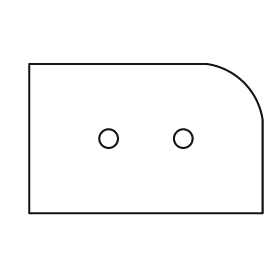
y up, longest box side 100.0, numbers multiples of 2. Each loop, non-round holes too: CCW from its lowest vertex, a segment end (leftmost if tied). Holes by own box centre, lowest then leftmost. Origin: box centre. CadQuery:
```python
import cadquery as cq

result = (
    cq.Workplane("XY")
    .moveTo(-50.0, -32.0)
    .lineTo(50.0, -32.0)
    .lineTo(50.0, 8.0)
    .threePointArc((42.0, 24.0), (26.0, 32.0))
    .lineTo(-50.0, 32.0)
    .close()
    .moveTo(-16.0, 0.0)
    .circle(4.0)
    .moveTo(16.0, 0.0)
    .circle(4.0)
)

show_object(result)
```